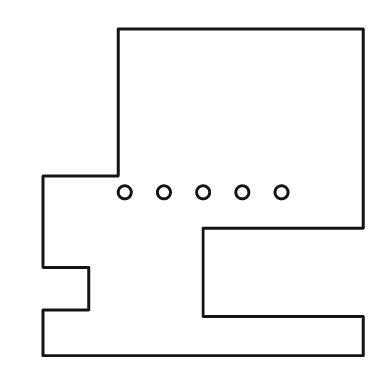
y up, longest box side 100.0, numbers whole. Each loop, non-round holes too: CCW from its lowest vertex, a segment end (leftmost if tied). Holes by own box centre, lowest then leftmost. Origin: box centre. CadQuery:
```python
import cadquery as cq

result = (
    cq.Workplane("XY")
    .moveTo(-49.0, -50.0)
    .lineTo(49.0, -50.0)
    .lineTo(49.0, -38.0)
    .lineTo(0.0, -38.0)
    .lineTo(0.0, -11.0)
    .lineTo(49.0, -11.0)
    .lineTo(49.0, 50.0)
    .lineTo(-26.0, 50.0)
    .lineTo(-26.0, 5.0)
    .lineTo(-49.0, 5.0)
    .lineTo(-49.0, -23.0)
    .lineTo(-35.0, -23.0)
    .lineTo(-35.0, -36.0)
    .lineTo(-49.0, -36.0)
    .close()
    .moveTo(-24.0, 0.0)
    .circle(2.0)
    .moveTo(-12.0, 0.0)
    .circle(2.0)
    .moveTo(0.0, 0.0)
    .circle(2.0)
    .moveTo(12.0, 0.0)
    .circle(2.0)
    .moveTo(24.0, 0.0)
    .circle(2.0)
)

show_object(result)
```